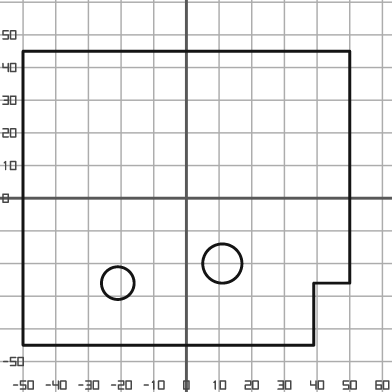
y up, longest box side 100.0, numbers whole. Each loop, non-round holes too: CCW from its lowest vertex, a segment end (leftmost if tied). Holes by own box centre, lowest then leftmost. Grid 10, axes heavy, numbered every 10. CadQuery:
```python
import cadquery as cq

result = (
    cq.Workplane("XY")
    .moveTo(-50.0, -45.0)
    .lineTo(39.0, -45.0)
    .lineTo(39.0, -26.0)
    .lineTo(50.0, -26.0)
    .lineTo(50.0, 45.0)
    .lineTo(-50.0, 45.0)
    .close()
    .moveTo(-21.0, -26.0)
    .circle(5.0)
    .moveTo(11.0, -20.0)
    .circle(6.0)
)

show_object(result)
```